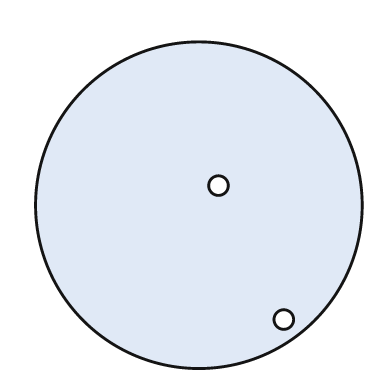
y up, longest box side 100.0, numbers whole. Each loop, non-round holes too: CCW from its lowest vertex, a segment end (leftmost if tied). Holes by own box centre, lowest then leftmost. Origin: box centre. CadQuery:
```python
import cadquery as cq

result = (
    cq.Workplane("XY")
    .moveTo(0.0, 0.0)
    .circle(50.0)
    .moveTo(26.0, -35.0)
    .circle(3.0)
    .moveTo(6.0, 6.0)
    .circle(3.0)
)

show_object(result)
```